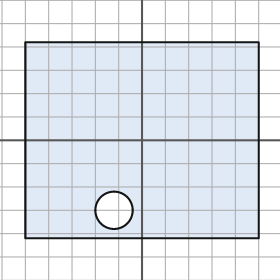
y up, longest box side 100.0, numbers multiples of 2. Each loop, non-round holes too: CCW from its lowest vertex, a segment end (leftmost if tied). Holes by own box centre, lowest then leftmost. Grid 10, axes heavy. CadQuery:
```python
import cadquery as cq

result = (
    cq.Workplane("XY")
    .moveTo(-50.0, -42.0)
    .lineTo(50.0, -42.0)
    .lineTo(50.0, 42.0)
    .lineTo(-50.0, 42.0)
    .close()
    .moveTo(-12.0, -30.0)
    .circle(8.0)
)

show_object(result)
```